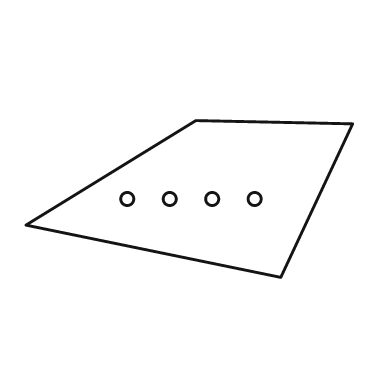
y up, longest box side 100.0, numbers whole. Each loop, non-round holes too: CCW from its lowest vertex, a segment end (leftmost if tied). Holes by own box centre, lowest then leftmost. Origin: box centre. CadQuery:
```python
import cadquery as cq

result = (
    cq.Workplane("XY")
    .moveTo(28.0, -24.0)
    .lineTo(50.0, 23.0)
    .lineTo(2.0, 24.0)
    .lineTo(-50.0, -8.0)
    .close()
    .moveTo(-19.0, 0.0)
    .circle(2.0)
    .moveTo(-6.0, 0.0)
    .circle(2.0)
    .moveTo(7.0, 0.0)
    .circle(2.0)
    .moveTo(20.0, 0.0)
    .circle(2.0)
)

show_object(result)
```